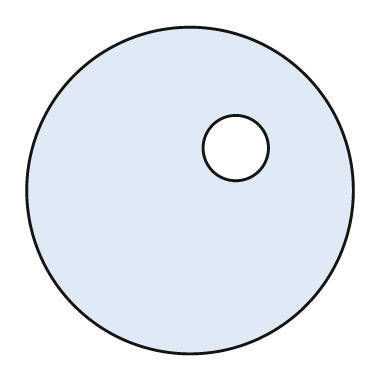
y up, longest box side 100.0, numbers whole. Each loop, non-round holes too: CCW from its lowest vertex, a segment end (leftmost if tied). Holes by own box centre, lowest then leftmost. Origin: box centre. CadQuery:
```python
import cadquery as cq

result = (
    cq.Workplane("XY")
    .moveTo(0.0, 0.0)
    .circle(50.0)
    .moveTo(14.0, 13.0)
    .circle(10.0)
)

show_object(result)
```